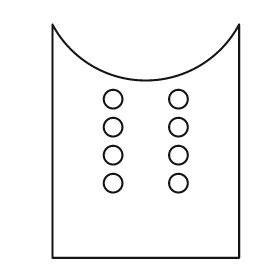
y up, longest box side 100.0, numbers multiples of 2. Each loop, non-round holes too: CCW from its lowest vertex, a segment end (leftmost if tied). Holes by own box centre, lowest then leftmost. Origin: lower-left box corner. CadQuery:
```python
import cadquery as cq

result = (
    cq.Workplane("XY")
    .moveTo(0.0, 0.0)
    .lineTo(80.0, 0.0)
    .lineTo(80.0, 100.0)
    .threePointArc((40.0, 76.0), (0.0, 100.0))
    .close()
    .moveTo(26.0, 32.0)
    .circle(4.0)
    .moveTo(54.0, 32.0)
    .circle(4.0)
    .moveTo(26.0, 44.0)
    .circle(4.0)
    .moveTo(54.0, 44.0)
    .circle(4.0)
    .moveTo(26.0, 56.0)
    .circle(4.0)
    .moveTo(54.0, 56.0)
    .circle(4.0)
    .moveTo(26.0, 68.0)
    .circle(4.0)
    .moveTo(54.0, 68.0)
    .circle(4.0)
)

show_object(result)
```